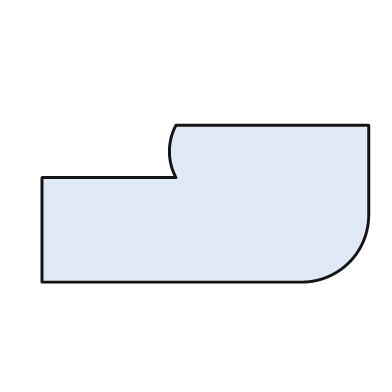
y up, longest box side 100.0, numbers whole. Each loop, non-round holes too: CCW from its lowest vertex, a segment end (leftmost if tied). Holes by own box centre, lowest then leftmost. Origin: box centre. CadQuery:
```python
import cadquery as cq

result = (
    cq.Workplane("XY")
    .moveTo(-50.0, -24.0)
    .lineTo(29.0, -24.0)
    .threePointArc((44.0, -18.0), (50.0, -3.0))
    .lineTo(50.0, 24.0)
    .lineTo(-9.0, 24.0)
    .threePointArc((-11.0, 16.0), (-9.0, 8.0))
    .lineTo(-50.0, 8.0)
    .close()
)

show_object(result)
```